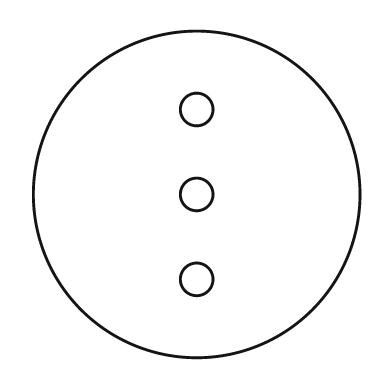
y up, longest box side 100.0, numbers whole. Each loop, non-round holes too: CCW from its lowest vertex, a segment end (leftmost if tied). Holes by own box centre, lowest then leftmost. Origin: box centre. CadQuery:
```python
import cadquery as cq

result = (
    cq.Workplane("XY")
    .moveTo(0.0, 0.0)
    .circle(50.0)
    .moveTo(0.0, -26.0)
    .circle(5.0)
    .moveTo(0.0, 0.0)
    .circle(5.0)
    .moveTo(0.0, 26.0)
    .circle(5.0)
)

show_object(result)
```